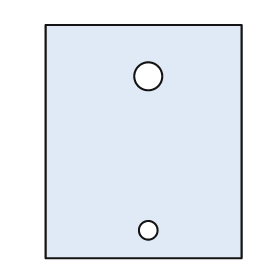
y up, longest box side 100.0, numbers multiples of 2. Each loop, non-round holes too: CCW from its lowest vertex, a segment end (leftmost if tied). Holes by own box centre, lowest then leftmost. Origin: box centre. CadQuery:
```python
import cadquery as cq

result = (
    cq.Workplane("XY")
    .moveTo(-42.0, -50.0)
    .lineTo(42.0, -50.0)
    .lineTo(42.0, 50.0)
    .lineTo(-42.0, 50.0)
    .close()
    .moveTo(2.0, -38.0)
    .circle(4.0)
    .moveTo(2.0, 28.0)
    .circle(6.0)
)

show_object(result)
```